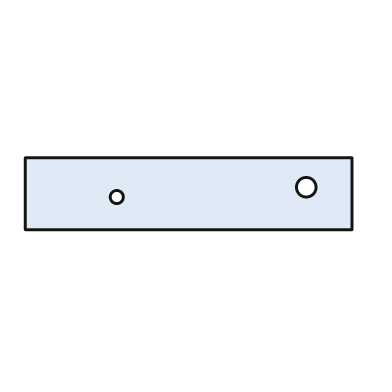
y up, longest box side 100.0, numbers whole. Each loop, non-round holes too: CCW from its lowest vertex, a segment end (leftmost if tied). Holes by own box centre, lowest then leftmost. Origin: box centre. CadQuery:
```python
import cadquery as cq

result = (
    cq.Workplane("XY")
    .moveTo(-50.0, -11.0)
    .lineTo(50.0, -11.0)
    .lineTo(50.0, 11.0)
    .lineTo(-50.0, 11.0)
    .close()
    .moveTo(-22.0, -1.0)
    .circle(2.0)
    .moveTo(36.0, 2.0)
    .circle(3.0)
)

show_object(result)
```